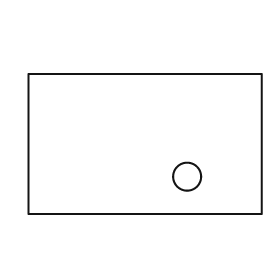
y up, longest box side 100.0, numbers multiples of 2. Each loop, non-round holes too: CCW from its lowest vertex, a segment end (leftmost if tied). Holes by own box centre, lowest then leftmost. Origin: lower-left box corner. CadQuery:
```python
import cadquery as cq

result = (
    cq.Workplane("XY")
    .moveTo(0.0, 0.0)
    .lineTo(100.0, 0.0)
    .lineTo(100.0, 60.0)
    .lineTo(0.0, 60.0)
    .close()
    .moveTo(68.0, 16.0)
    .circle(6.0)
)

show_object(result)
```